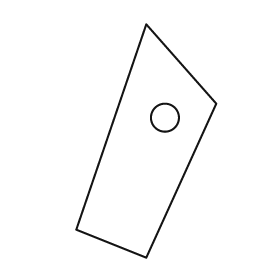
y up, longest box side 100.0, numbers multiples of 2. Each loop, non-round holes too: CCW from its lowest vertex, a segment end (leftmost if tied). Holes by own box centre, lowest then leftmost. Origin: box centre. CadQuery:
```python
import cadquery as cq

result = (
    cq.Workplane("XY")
    .moveTo(0.0, -50.0)
    .lineTo(30.0, 16.0)
    .lineTo(0.0, 50.0)
    .lineTo(-30.0, -38.0)
    .close()
    .moveTo(8.0, 10.0)
    .circle(6.0)
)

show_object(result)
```